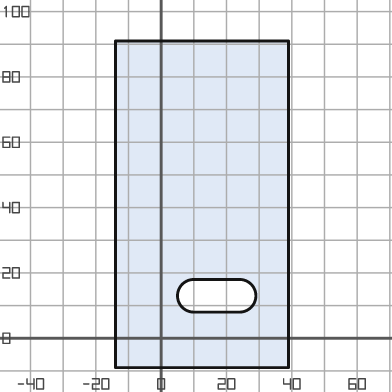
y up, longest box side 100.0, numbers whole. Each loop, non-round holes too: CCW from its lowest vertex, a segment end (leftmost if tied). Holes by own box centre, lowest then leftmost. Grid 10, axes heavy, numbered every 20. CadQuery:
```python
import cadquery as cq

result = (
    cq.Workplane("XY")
    .moveTo(-14.0, -9.0)
    .lineTo(39.0, -9.0)
    .lineTo(39.0, 91.0)
    .lineTo(-14.0, 91.0)
    .close()
    .moveTo(10.0, 8.0)
    .lineTo(24.0, 8.0)
    .threePointArc((29.0, 13.0), (24.0, 18.0))
    .lineTo(10.0, 18.0)
    .threePointArc((5.0, 13.0), (10.0, 8.0))
    .close()
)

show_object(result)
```